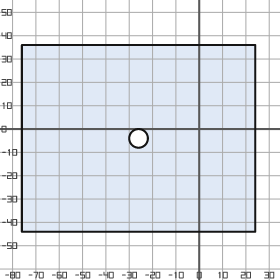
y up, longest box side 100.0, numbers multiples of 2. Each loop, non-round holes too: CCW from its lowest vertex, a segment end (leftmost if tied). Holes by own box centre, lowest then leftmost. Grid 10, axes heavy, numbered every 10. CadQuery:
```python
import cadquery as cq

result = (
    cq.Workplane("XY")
    .moveTo(-76.0, -44.0)
    .lineTo(24.0, -44.0)
    .lineTo(24.0, 36.0)
    .lineTo(-76.0, 36.0)
    .close()
    .moveTo(-26.0, -4.0)
    .circle(4.0)
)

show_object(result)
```